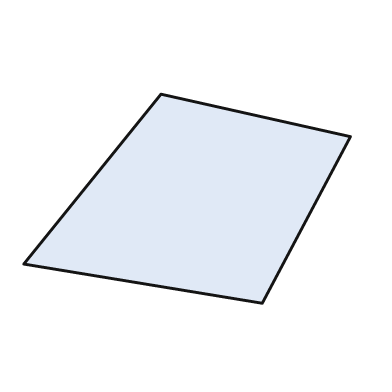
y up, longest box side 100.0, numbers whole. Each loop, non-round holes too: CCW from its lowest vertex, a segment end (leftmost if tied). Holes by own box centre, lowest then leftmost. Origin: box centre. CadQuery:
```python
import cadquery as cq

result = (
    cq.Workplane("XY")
    .moveTo(23.0, -32.0)
    .lineTo(50.0, 19.0)
    .lineTo(-8.0, 32.0)
    .lineTo(-50.0, -20.0)
    .close()
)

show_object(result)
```